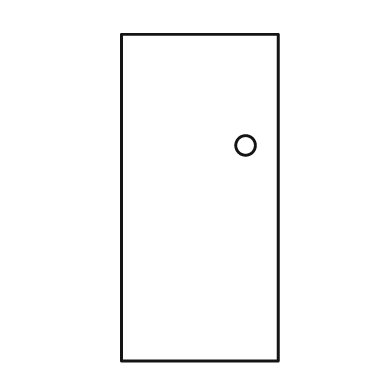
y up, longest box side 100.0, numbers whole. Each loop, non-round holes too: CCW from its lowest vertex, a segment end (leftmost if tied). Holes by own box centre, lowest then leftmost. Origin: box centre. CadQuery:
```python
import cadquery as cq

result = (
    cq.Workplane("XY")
    .moveTo(-24.0, -50.0)
    .lineTo(24.0, -50.0)
    .lineTo(24.0, 50.0)
    .lineTo(-24.0, 50.0)
    .close()
    .moveTo(14.0, 16.0)
    .circle(3.0)
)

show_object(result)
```